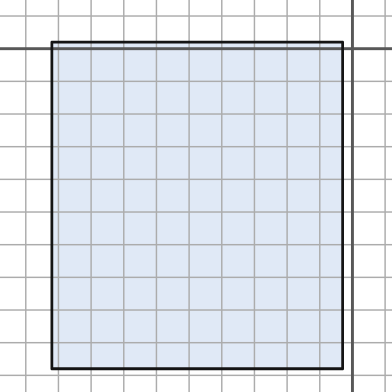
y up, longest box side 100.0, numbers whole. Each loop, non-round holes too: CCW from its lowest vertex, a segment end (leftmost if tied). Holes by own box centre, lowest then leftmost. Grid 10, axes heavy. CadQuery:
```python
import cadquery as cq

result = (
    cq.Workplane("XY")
    .moveTo(-92.0, -98.0)
    .lineTo(-3.0, -98.0)
    .lineTo(-3.0, 2.0)
    .lineTo(-92.0, 2.0)
    .close()
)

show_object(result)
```